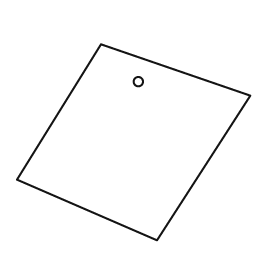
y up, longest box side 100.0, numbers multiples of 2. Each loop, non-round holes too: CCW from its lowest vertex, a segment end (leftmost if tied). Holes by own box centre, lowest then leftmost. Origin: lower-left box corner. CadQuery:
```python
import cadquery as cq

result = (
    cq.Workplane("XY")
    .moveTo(60.0, 0.0)
    .lineTo(100.0, 62.0)
    .lineTo(36.0, 84.0)
    .lineTo(0.0, 26.0)
    .close()
    .moveTo(52.0, 68.0)
    .circle(2.0)
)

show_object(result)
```